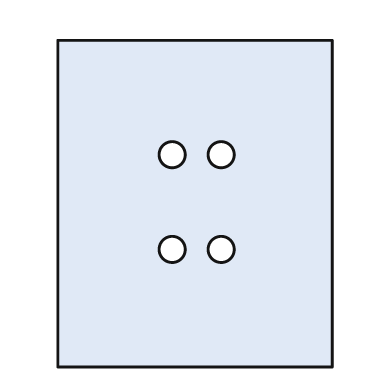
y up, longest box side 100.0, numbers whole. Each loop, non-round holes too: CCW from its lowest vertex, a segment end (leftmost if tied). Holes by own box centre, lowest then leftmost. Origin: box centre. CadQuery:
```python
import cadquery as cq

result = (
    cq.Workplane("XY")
    .moveTo(-42.0, -50.0)
    .lineTo(42.0, -50.0)
    .lineTo(42.0, 50.0)
    .lineTo(-42.0, 50.0)
    .close()
    .moveTo(-7.0, -14.0)
    .circle(4.0)
    .moveTo(8.0, -14.0)
    .circle(4.0)
    .moveTo(-7.0, 15.0)
    .circle(4.0)
    .moveTo(8.0, 15.0)
    .circle(4.0)
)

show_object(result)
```